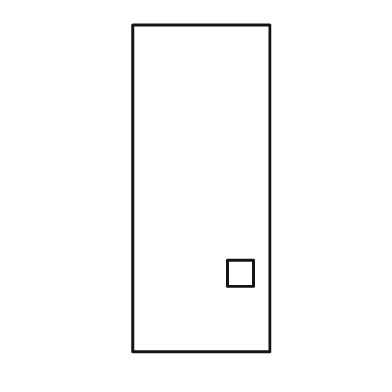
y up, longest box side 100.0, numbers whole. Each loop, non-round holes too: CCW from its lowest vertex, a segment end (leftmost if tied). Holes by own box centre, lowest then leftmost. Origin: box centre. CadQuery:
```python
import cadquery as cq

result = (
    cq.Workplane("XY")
    .moveTo(-21.0, -50.0)
    .lineTo(21.0, -50.0)
    .lineTo(21.0, 50.0)
    .lineTo(-21.0, 50.0)
    .close()
    .moveTo(8.0, -30.0)
    .lineTo(16.0, -30.0)
    .lineTo(16.0, -22.0)
    .lineTo(8.0, -22.0)
    .close()
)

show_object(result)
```